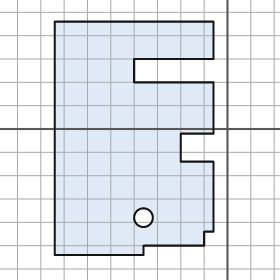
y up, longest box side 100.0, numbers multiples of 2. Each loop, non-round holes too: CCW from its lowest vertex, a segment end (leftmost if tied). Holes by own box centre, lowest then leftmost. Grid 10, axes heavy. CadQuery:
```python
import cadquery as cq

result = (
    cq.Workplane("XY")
    .moveTo(-74.0, -54.0)
    .lineTo(-36.0, -54.0)
    .lineTo(-36.0, -50.0)
    .lineTo(-10.0, -50.0)
    .lineTo(-10.0, -44.0)
    .lineTo(-6.0, -44.0)
    .lineTo(-6.0, -14.0)
    .lineTo(-20.0, -14.0)
    .lineTo(-20.0, -2.0)
    .lineTo(-6.0, -2.0)
    .lineTo(-6.0, 20.0)
    .lineTo(-40.0, 20.0)
    .lineTo(-40.0, 30.0)
    .lineTo(-6.0, 30.0)
    .lineTo(-6.0, 46.0)
    .lineTo(-74.0, 46.0)
    .close()
    .moveTo(-36.0, -38.0)
    .circle(4.0)
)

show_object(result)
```